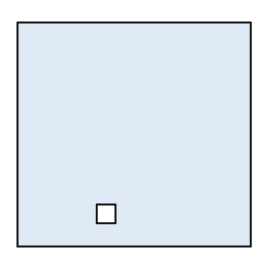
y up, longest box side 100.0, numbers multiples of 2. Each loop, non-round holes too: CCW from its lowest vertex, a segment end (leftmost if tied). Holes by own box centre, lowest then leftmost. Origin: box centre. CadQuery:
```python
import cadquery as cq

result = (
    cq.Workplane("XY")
    .moveTo(-50.0, -48.0)
    .lineTo(50.0, -48.0)
    .lineTo(50.0, 48.0)
    .lineTo(-50.0, 48.0)
    .close()
    .moveTo(-16.0, -38.0)
    .lineTo(-8.0, -38.0)
    .lineTo(-8.0, -30.0)
    .lineTo(-16.0, -30.0)
    .close()
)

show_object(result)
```